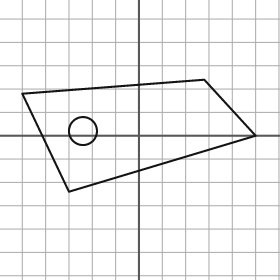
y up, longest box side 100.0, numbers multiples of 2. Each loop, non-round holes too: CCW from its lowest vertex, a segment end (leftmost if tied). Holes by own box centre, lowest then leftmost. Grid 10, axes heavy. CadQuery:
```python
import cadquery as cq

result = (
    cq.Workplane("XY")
    .moveTo(-30.0, -24.0)
    .lineTo(50.0, 0.0)
    .lineTo(28.0, 24.0)
    .lineTo(-50.0, 18.0)
    .close()
    .moveTo(-24.0, 2.0)
    .circle(6.0)
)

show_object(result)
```